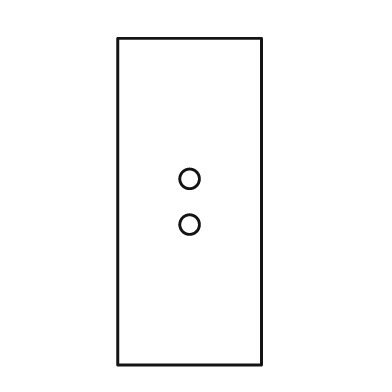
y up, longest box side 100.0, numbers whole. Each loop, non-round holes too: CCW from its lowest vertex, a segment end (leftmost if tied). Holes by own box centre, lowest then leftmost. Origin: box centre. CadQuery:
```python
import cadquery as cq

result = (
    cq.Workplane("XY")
    .moveTo(-22.0, -50.0)
    .lineTo(22.0, -50.0)
    .lineTo(22.0, 50.0)
    .lineTo(-22.0, 50.0)
    .close()
    .moveTo(0.0, -7.0)
    .circle(3.0)
    .moveTo(0.0, 7.0)
    .circle(3.0)
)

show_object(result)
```